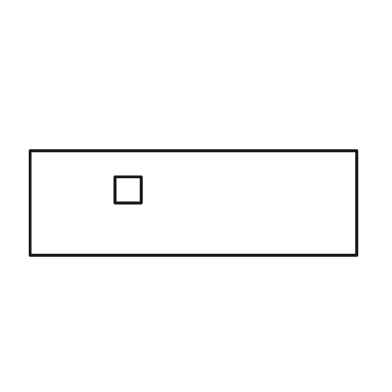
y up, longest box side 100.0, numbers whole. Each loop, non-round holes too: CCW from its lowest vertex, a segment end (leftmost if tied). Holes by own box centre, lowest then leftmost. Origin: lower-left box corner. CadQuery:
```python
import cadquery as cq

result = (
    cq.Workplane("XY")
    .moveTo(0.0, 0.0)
    .lineTo(100.0, 0.0)
    .lineTo(100.0, 32.0)
    .lineTo(0.0, 32.0)
    .close()
    .moveTo(26.0, 16.0)
    .lineTo(34.0, 16.0)
    .lineTo(34.0, 24.0)
    .lineTo(26.0, 24.0)
    .close()
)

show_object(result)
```